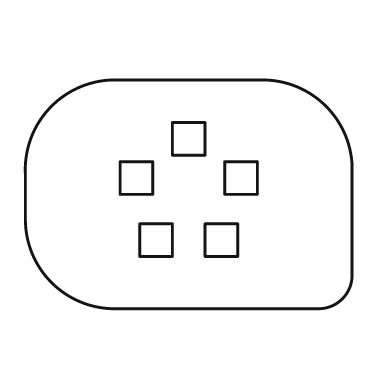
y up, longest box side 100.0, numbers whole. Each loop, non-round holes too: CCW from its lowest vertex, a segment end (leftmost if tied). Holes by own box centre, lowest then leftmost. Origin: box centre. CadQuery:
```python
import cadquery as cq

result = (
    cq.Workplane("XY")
    .moveTo(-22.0, -35.0)
    .lineTo(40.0, -35.0)
    .threePointArc((47.0, -32.0), (50.0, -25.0))
    .lineTo(50.0, 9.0)
    .threePointArc((42.0, 27.0), (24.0, 35.0))
    .lineTo(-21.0, 35.0)
    .threePointArc((-42.0, 27.0), (-50.0, 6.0))
    .lineTo(-50.0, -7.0)
    .threePointArc((-42.0, -27.0), (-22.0, -35.0))
    .close()
    .moveTo(-15.0, -19.0)
    .lineTo(-5.0, -19.0)
    .lineTo(-5.0, -9.0)
    .lineTo(-15.0, -9.0)
    .close()
    .moveTo(5.0, -19.0)
    .lineTo(15.0, -19.0)
    .lineTo(15.0, -9.0)
    .lineTo(5.0, -9.0)
    .close()
    .moveTo(-21.0, 0.0)
    .lineTo(-11.0, 0.0)
    .lineTo(-11.0, 10.0)
    .lineTo(-21.0, 10.0)
    .close()
    .moveTo(11.0, 0.0)
    .lineTo(21.0, 0.0)
    .lineTo(21.0, 10.0)
    .lineTo(11.0, 10.0)
    .close()
    .moveTo(-5.0, 12.0)
    .lineTo(5.0, 12.0)
    .lineTo(5.0, 22.0)
    .lineTo(-5.0, 22.0)
    .close()
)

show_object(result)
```